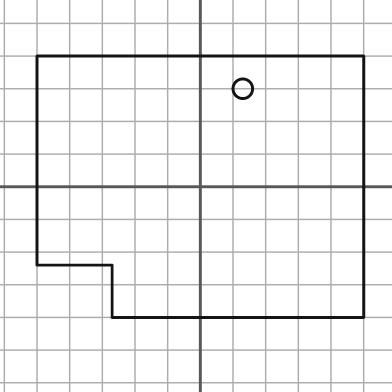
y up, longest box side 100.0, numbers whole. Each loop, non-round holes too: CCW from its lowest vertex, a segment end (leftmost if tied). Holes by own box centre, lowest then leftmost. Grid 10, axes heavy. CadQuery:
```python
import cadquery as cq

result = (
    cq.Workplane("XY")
    .moveTo(-27.0, -40.0)
    .lineTo(50.0, -40.0)
    .lineTo(50.0, 40.0)
    .lineTo(-50.0, 40.0)
    .lineTo(-50.0, -24.0)
    .lineTo(-27.0, -24.0)
    .close()
    .moveTo(13.0, 30.0)
    .circle(3.0)
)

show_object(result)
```